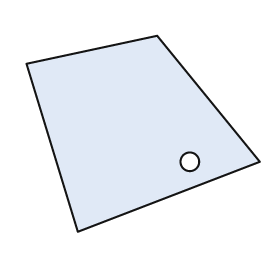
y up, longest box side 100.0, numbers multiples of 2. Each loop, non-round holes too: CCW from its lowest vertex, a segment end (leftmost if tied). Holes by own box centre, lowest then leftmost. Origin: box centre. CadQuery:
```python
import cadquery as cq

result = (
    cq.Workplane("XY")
    .moveTo(-28.0, -42.0)
    .lineTo(50.0, -12.0)
    .lineTo(6.0, 42.0)
    .lineTo(-50.0, 30.0)
    .close()
    .moveTo(20.0, -12.0)
    .circle(4.0)
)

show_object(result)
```